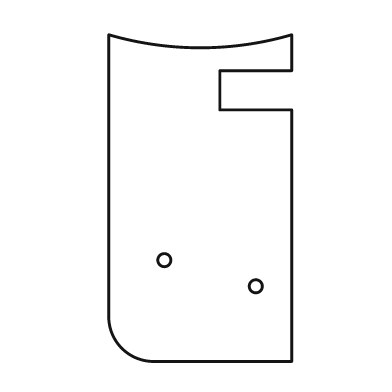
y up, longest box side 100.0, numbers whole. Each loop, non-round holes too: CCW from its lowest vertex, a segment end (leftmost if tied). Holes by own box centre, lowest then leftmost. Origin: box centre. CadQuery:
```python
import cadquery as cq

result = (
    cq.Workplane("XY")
    .moveTo(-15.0, -50.0)
    .lineTo(28.0, -50.0)
    .lineTo(28.0, 27.0)
    .lineTo(6.0, 27.0)
    .lineTo(6.0, 39.0)
    .lineTo(28.0, 39.0)
    .lineTo(28.0, 50.0)
    .threePointArc((0.0, 46.0), (-28.0, 50.0))
    .lineTo(-28.0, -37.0)
    .threePointArc((-24.0, -46.0), (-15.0, -50.0))
    .close()
    .moveTo(17.0, -27.0)
    .circle(2.0)
    .moveTo(-11.0, -19.0)
    .circle(2.0)
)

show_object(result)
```